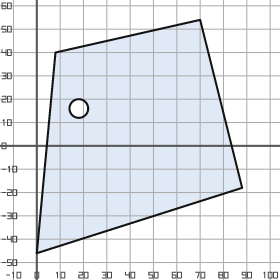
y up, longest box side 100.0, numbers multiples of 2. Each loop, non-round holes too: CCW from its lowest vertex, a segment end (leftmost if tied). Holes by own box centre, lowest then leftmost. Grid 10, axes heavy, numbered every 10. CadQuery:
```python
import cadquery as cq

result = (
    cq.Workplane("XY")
    .moveTo(0.0, -46.0)
    .lineTo(88.0, -18.0)
    .lineTo(70.0, 54.0)
    .lineTo(8.0, 40.0)
    .close()
    .moveTo(18.0, 16.0)
    .circle(4.0)
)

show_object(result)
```